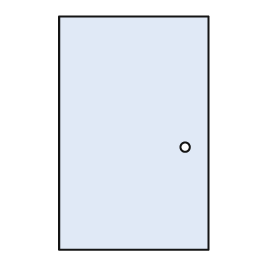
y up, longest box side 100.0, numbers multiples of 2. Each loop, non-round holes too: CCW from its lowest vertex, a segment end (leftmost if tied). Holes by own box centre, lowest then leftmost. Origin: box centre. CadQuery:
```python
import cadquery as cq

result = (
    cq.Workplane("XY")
    .moveTo(-32.0, -50.0)
    .lineTo(32.0, -50.0)
    .lineTo(32.0, 50.0)
    .lineTo(-32.0, 50.0)
    .close()
    .moveTo(22.0, -6.0)
    .circle(2.0)
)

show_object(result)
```